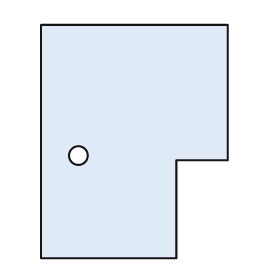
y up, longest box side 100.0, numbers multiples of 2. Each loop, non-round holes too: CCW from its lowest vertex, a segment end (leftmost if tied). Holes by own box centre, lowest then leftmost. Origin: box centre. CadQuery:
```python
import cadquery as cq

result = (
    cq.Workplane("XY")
    .moveTo(-40.0, -50.0)
    .lineTo(18.0, -50.0)
    .lineTo(18.0, -8.0)
    .lineTo(40.0, -8.0)
    .lineTo(40.0, 50.0)
    .lineTo(-40.0, 50.0)
    .close()
    .moveTo(-24.0, -6.0)
    .circle(4.0)
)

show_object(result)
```